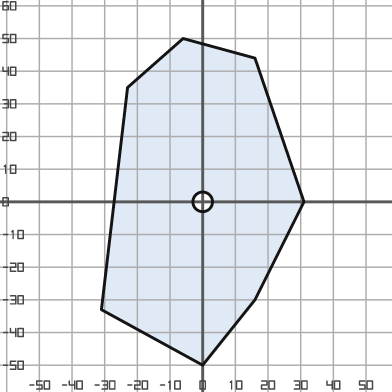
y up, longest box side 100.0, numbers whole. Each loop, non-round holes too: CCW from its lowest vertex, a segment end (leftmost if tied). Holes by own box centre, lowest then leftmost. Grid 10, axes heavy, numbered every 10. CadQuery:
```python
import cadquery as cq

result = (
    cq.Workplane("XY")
    .moveTo(0.0, -50.0)
    .lineTo(16.0, -30.0)
    .lineTo(31.0, 0.0)
    .lineTo(16.0, 44.0)
    .lineTo(-6.0, 50.0)
    .lineTo(-23.0, 35.0)
    .lineTo(-31.0, -33.0)
    .close()
    .moveTo(0.0, 0.0)
    .circle(3.0)
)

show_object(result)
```